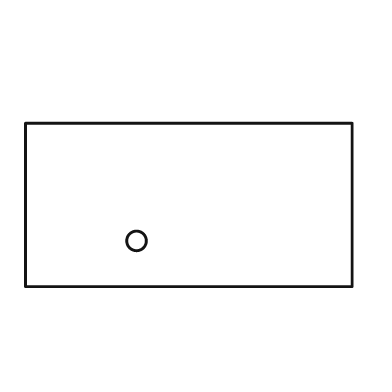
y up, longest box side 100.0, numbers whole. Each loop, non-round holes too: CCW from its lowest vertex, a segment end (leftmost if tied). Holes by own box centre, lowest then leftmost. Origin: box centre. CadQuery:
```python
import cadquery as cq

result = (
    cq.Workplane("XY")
    .moveTo(-50.0, -25.0)
    .lineTo(50.0, -25.0)
    .lineTo(50.0, 25.0)
    .lineTo(-50.0, 25.0)
    .close()
    .moveTo(-16.0, -11.0)
    .circle(3.0)
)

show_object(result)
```